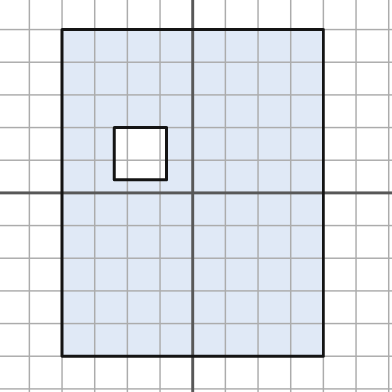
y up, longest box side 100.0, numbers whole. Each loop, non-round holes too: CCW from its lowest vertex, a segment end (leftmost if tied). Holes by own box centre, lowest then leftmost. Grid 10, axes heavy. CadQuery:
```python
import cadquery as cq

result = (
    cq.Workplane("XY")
    .moveTo(-40.0, -50.0)
    .lineTo(40.0, -50.0)
    .lineTo(40.0, 50.0)
    .lineTo(-40.0, 50.0)
    .close()
    .moveTo(-24.0, 4.0)
    .lineTo(-8.0, 4.0)
    .lineTo(-8.0, 20.0)
    .lineTo(-24.0, 20.0)
    .close()
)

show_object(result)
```